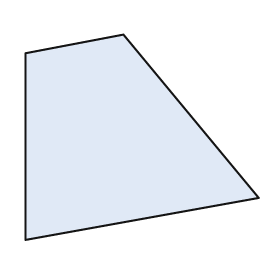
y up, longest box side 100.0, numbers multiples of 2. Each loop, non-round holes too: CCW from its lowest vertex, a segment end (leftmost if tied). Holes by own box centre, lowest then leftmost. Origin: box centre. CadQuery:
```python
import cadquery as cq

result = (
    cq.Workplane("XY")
    .moveTo(-50.0, -44.0)
    .lineTo(50.0, -26.0)
    .lineTo(-8.0, 44.0)
    .lineTo(-50.0, 36.0)
    .close()
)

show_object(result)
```